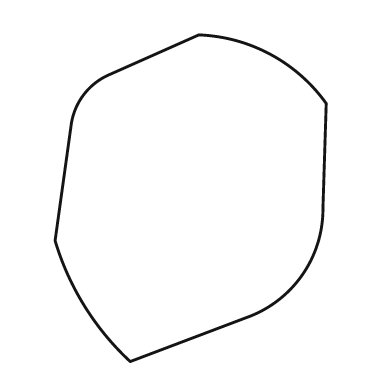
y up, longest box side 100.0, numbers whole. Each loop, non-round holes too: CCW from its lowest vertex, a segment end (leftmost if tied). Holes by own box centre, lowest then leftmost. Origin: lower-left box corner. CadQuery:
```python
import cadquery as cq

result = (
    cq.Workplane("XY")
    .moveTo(23.0, 0.0)
    .lineTo(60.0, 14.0)
    .threePointArc((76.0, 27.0), (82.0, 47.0))
    .lineTo(83.0, 79.0)
    .threePointArc((66.0, 94.0), (44.0, 100.0))
    .lineTo(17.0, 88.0)
    .threePointArc((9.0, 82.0), (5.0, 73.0))
    .lineTo(0.0, 37.0)
    .threePointArc((9.0, 17.0), (23.0, 0.0))
    .close()
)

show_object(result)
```